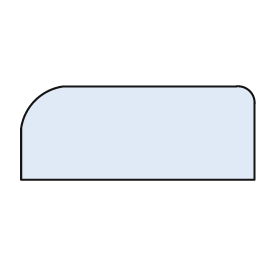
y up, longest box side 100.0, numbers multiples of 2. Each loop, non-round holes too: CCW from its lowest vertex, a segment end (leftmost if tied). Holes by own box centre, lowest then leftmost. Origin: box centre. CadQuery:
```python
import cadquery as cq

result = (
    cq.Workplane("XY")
    .moveTo(-50.0, -20.0)
    .lineTo(50.0, -20.0)
    .lineTo(50.0, 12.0)
    .threePointArc((48.0, 18.0), (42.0, 20.0))
    .lineTo(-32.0, 20.0)
    .threePointArc((-44.0, 14.0), (-50.0, 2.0))
    .close()
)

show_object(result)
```